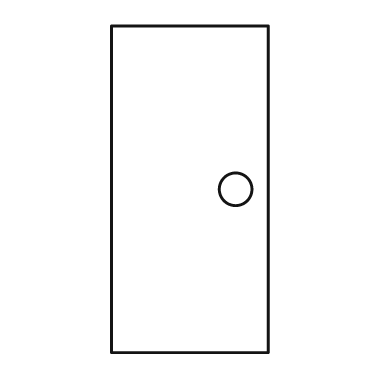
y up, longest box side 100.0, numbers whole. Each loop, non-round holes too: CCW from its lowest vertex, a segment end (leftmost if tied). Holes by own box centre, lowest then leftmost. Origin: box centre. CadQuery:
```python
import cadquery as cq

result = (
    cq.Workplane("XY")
    .moveTo(-24.0, -50.0)
    .lineTo(24.0, -50.0)
    .lineTo(24.0, 50.0)
    .lineTo(-24.0, 50.0)
    .close()
    .moveTo(14.0, 0.0)
    .circle(5.0)
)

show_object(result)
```